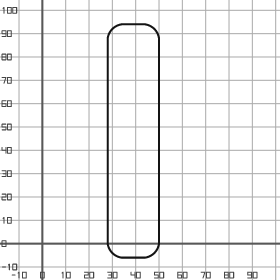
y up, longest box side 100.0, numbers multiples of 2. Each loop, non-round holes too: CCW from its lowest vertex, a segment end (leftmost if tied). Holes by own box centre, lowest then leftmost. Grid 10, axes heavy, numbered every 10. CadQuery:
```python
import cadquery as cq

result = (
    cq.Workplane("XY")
    .moveTo(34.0, -6.0)
    .lineTo(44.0, -6.0)
    .threePointArc((48.0, -4.0), (50.0, 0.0))
    .lineTo(50.0, 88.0)
    .threePointArc((48.0, 92.0), (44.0, 94.0))
    .lineTo(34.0, 94.0)
    .threePointArc((30.0, 92.0), (28.0, 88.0))
    .lineTo(28.0, 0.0)
    .threePointArc((30.0, -4.0), (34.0, -6.0))
    .close()
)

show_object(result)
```